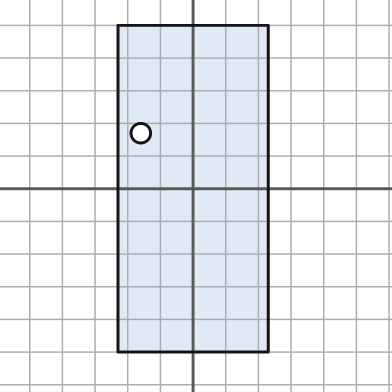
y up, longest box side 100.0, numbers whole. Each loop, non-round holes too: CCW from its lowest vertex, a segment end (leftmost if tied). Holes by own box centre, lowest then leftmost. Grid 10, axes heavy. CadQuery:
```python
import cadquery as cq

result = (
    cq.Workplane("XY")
    .moveTo(-23.0, -50.0)
    .lineTo(23.0, -50.0)
    .lineTo(23.0, 50.0)
    .lineTo(-23.0, 50.0)
    .close()
    .moveTo(-16.0, 17.0)
    .circle(3.0)
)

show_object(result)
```